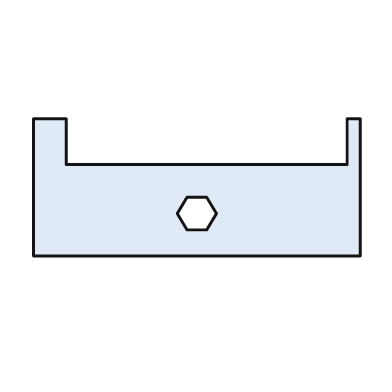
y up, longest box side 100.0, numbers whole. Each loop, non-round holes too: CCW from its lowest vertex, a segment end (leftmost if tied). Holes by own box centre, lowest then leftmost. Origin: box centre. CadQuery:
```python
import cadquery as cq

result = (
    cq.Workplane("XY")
    .moveTo(-50.0, -21.0)
    .lineTo(50.0, -21.0)
    .lineTo(50.0, 21.0)
    .lineTo(46.0, 21.0)
    .lineTo(46.0, 7.0)
    .lineTo(-40.0, 7.0)
    .lineTo(-40.0, 21.0)
    .lineTo(-50.0, 21.0)
    .close()
    .moveTo(-3.0, -13.0)
    .lineTo(3.0, -13.0)
    .lineTo(6.0, -8.0)
    .lineTo(3.0, -3.0)
    .lineTo(-3.0, -3.0)
    .lineTo(-6.0, -8.0)
    .close()
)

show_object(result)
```